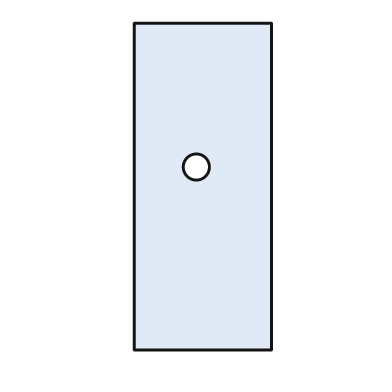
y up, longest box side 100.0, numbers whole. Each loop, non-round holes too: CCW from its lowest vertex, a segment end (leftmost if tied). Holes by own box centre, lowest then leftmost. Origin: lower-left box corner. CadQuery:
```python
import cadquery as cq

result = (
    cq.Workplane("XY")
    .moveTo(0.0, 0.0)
    .lineTo(42.0, 0.0)
    .lineTo(42.0, 100.0)
    .lineTo(0.0, 100.0)
    .close()
    .moveTo(19.0, 56.0)
    .circle(4.0)
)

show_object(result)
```